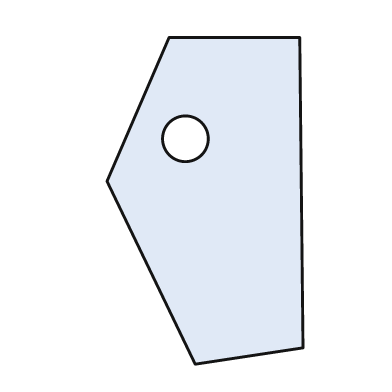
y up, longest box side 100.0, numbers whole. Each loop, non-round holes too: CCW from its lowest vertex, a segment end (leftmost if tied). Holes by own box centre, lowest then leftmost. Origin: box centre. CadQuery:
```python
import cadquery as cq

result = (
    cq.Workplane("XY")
    .moveTo(-3.0, -50.0)
    .lineTo(30.0, -45.0)
    .lineTo(29.0, 50.0)
    .lineTo(-11.0, 50.0)
    .lineTo(-30.0, 6.0)
    .close()
    .moveTo(-6.0, 19.0)
    .circle(7.0)
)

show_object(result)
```